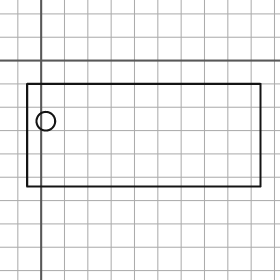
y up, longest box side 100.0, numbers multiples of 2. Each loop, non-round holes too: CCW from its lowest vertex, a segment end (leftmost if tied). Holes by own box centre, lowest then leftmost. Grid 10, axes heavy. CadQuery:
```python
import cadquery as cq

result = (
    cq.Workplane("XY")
    .moveTo(-6.0, -54.0)
    .lineTo(94.0, -54.0)
    .lineTo(94.0, -10.0)
    .lineTo(-6.0, -10.0)
    .close()
    .moveTo(2.0, -26.0)
    .circle(4.0)
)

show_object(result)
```